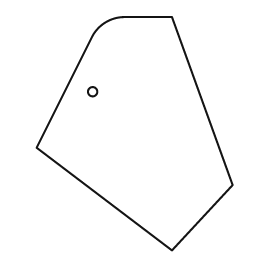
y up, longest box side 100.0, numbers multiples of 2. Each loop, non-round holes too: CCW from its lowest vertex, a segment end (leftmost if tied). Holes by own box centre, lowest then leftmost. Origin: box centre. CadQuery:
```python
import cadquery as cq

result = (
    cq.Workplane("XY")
    .moveTo(16.0, -50.0)
    .lineTo(42.0, -22.0)
    .lineTo(16.0, 50.0)
    .lineTo(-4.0, 50.0)
    .threePointArc((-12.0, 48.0), (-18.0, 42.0))
    .lineTo(-42.0, -6.0)
    .close()
    .moveTo(-18.0, 18.0)
    .circle(2.0)
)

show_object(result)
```